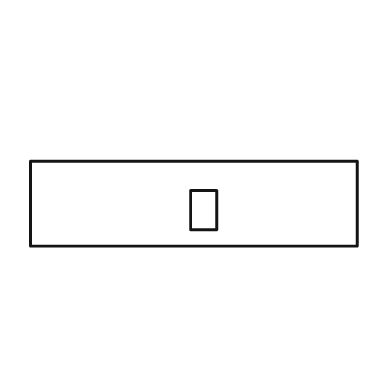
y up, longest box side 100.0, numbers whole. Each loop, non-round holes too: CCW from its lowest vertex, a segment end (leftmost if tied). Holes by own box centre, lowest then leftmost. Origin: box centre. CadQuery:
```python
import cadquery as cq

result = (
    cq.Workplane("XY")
    .moveTo(-50.0, -13.0)
    .lineTo(50.0, -13.0)
    .lineTo(50.0, 13.0)
    .lineTo(-50.0, 13.0)
    .close()
    .moveTo(-1.0, -8.0)
    .lineTo(7.0, -8.0)
    .lineTo(7.0, 4.0)
    .lineTo(-1.0, 4.0)
    .close()
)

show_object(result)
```